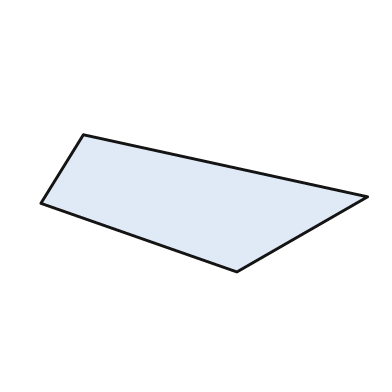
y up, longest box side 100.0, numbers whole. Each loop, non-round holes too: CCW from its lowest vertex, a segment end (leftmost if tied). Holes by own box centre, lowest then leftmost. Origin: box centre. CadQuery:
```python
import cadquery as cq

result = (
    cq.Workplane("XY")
    .moveTo(10.0, -21.0)
    .lineTo(50.0, 2.0)
    .lineTo(-37.0, 21.0)
    .lineTo(-50.0, 0.0)
    .close()
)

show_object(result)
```